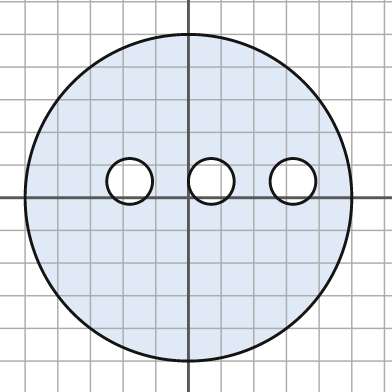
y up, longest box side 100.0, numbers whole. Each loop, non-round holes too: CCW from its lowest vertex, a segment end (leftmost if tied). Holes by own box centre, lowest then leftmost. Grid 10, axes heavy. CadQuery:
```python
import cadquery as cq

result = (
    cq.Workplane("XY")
    .moveTo(0.0, 0.0)
    .circle(50.0)
    .moveTo(-18.0, 5.0)
    .circle(7.0)
    .moveTo(7.0, 5.0)
    .circle(7.0)
    .moveTo(32.0, 5.0)
    .circle(7.0)
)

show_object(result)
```